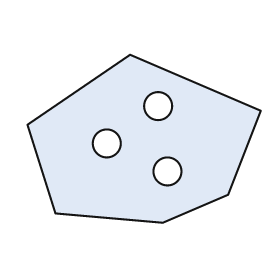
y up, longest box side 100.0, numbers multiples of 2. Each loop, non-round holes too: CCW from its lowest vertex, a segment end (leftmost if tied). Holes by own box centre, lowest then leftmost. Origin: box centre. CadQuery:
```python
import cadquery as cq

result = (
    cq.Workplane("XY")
    .moveTo(8.0, -36.0)
    .lineTo(36.0, -24.0)
    .lineTo(50.0, 12.0)
    .lineTo(-6.0, 36.0)
    .lineTo(-50.0, 6.0)
    .lineTo(-38.0, -32.0)
    .close()
    .moveTo(10.0, -14.0)
    .circle(6.0)
    .moveTo(-16.0, -2.0)
    .circle(6.0)
    .moveTo(6.0, 14.0)
    .circle(6.0)
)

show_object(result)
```